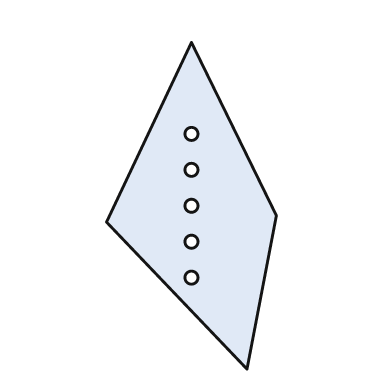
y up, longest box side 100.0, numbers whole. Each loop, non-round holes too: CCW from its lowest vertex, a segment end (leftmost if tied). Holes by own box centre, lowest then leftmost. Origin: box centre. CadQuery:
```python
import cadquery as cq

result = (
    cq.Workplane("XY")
    .moveTo(17.0, -50.0)
    .lineTo(26.0, -3.0)
    .lineTo(0.0, 50.0)
    .lineTo(-26.0, -5.0)
    .close()
    .moveTo(0.0, -22.0)
    .circle(2.0)
    .moveTo(0.0, -11.0)
    .circle(2.0)
    .moveTo(0.0, 0.0)
    .circle(2.0)
    .moveTo(0.0, 11.0)
    .circle(2.0)
    .moveTo(0.0, 22.0)
    .circle(2.0)
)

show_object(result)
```